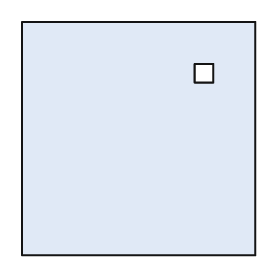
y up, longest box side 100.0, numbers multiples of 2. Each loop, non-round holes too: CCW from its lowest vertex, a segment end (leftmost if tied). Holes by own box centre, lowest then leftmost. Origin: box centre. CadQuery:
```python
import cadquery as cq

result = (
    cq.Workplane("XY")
    .moveTo(-50.0, -50.0)
    .lineTo(50.0, -50.0)
    .lineTo(50.0, 50.0)
    .lineTo(-50.0, 50.0)
    .close()
    .moveTo(24.0, 24.0)
    .lineTo(32.0, 24.0)
    .lineTo(32.0, 32.0)
    .lineTo(24.0, 32.0)
    .close()
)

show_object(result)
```